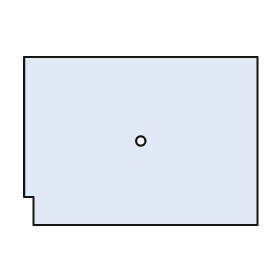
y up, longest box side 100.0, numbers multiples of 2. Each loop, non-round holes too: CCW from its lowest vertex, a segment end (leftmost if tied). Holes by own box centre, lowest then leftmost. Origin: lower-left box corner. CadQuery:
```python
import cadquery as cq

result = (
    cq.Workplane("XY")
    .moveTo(4.0, 0.0)
    .lineTo(100.0, 0.0)
    .lineTo(100.0, 72.0)
    .lineTo(0.0, 72.0)
    .lineTo(0.0, 12.0)
    .lineTo(4.0, 12.0)
    .close()
    .moveTo(50.0, 36.0)
    .circle(2.0)
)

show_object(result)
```